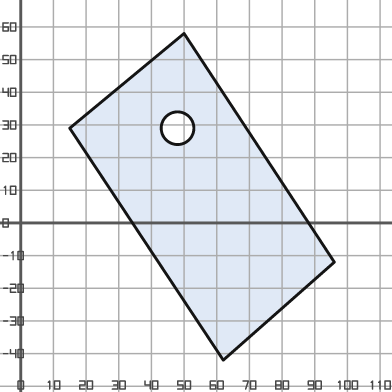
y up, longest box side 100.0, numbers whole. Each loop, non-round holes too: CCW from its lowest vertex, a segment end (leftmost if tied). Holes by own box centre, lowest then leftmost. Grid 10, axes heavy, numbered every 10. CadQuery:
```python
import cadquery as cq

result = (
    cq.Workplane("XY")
    .moveTo(62.0, -42.0)
    .lineTo(96.0, -12.0)
    .lineTo(50.0, 58.0)
    .lineTo(15.0, 29.0)
    .close()
    .moveTo(48.0, 29.0)
    .circle(5.0)
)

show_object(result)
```